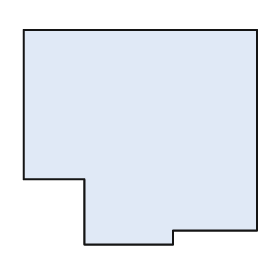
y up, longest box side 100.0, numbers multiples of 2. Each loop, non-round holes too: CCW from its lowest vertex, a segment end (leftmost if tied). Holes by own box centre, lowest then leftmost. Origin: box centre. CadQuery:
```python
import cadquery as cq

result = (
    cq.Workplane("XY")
    .moveTo(-24.0, -46.0)
    .lineTo(14.0, -46.0)
    .lineTo(14.0, -40.0)
    .lineTo(50.0, -40.0)
    .lineTo(50.0, 46.0)
    .lineTo(-50.0, 46.0)
    .lineTo(-50.0, -18.0)
    .lineTo(-24.0, -18.0)
    .close()
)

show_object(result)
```